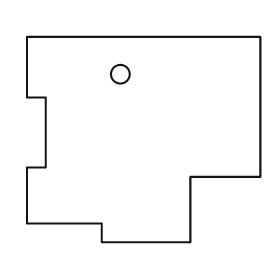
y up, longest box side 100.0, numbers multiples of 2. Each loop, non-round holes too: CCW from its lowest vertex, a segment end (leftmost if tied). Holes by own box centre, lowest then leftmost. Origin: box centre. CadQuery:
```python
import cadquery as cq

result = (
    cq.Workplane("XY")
    .moveTo(-18.0, -44.0)
    .lineTo(20.0, -44.0)
    .lineTo(20.0, -16.0)
    .lineTo(50.0, -16.0)
    .lineTo(50.0, 44.0)
    .lineTo(-50.0, 44.0)
    .lineTo(-50.0, 18.0)
    .lineTo(-42.0, 18.0)
    .lineTo(-42.0, -12.0)
    .lineTo(-50.0, -12.0)
    .lineTo(-50.0, -36.0)
    .lineTo(-18.0, -36.0)
    .close()
    .moveTo(-10.0, 28.0)
    .circle(4.0)
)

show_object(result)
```